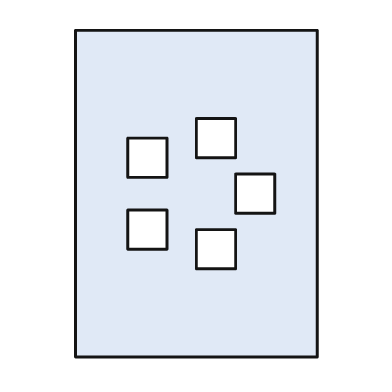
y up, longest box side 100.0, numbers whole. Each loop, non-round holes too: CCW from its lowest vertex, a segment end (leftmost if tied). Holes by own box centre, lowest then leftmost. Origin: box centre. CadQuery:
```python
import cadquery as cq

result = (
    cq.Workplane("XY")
    .moveTo(-37.0, -50.0)
    .lineTo(37.0, -50.0)
    .lineTo(37.0, 50.0)
    .lineTo(-37.0, 50.0)
    .close()
    .moveTo(0.0, -23.0)
    .lineTo(12.0, -23.0)
    .lineTo(12.0, -11.0)
    .lineTo(0.0, -11.0)
    .close()
    .moveTo(-21.0, -17.0)
    .lineTo(-9.0, -17.0)
    .lineTo(-9.0, -5.0)
    .lineTo(-21.0, -5.0)
    .close()
    .moveTo(12.0, -6.0)
    .lineTo(24.0, -6.0)
    .lineTo(24.0, 6.0)
    .lineTo(12.0, 6.0)
    .close()
    .moveTo(-21.0, 5.0)
    .lineTo(-9.0, 5.0)
    .lineTo(-9.0, 17.0)
    .lineTo(-21.0, 17.0)
    .close()
    .moveTo(0.0, 11.0)
    .lineTo(12.0, 11.0)
    .lineTo(12.0, 23.0)
    .lineTo(0.0, 23.0)
    .close()
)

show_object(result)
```